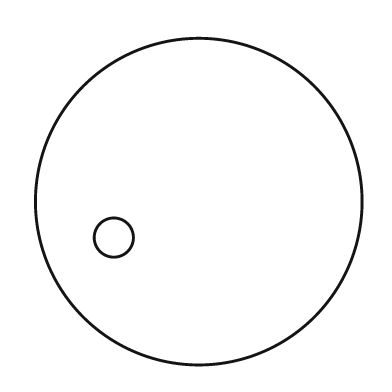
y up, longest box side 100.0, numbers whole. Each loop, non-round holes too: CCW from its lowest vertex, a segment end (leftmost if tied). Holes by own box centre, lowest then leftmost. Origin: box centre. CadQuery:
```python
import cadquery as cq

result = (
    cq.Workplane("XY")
    .moveTo(0.0, 0.0)
    .circle(50.0)
    .moveTo(-26.0, -11.0)
    .circle(6.0)
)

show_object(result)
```